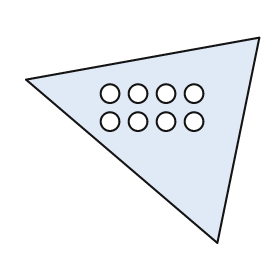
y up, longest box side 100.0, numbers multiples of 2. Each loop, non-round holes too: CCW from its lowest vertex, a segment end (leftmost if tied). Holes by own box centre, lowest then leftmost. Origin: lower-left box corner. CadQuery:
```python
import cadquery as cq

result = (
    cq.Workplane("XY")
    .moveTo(82.0, 0.0)
    .lineTo(100.0, 88.0)
    .lineTo(0.0, 70.0)
    .close()
    .moveTo(36.0, 52.0)
    .circle(4.0)
    .moveTo(48.0, 52.0)
    .circle(4.0)
    .moveTo(60.0, 52.0)
    .circle(4.0)
    .moveTo(72.0, 52.0)
    .circle(4.0)
    .moveTo(36.0, 64.0)
    .circle(4.0)
    .moveTo(48.0, 64.0)
    .circle(4.0)
    .moveTo(60.0, 64.0)
    .circle(4.0)
    .moveTo(72.0, 64.0)
    .circle(4.0)
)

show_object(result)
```